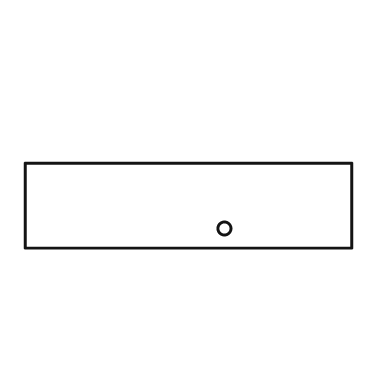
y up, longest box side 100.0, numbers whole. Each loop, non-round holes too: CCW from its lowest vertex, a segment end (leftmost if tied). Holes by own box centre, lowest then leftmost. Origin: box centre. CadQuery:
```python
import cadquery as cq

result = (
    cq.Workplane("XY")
    .moveTo(-50.0, -13.0)
    .lineTo(50.0, -13.0)
    .lineTo(50.0, 13.0)
    .lineTo(-50.0, 13.0)
    .close()
    .moveTo(11.0, -7.0)
    .circle(2.0)
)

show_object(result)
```